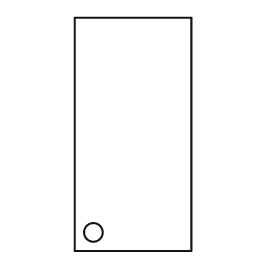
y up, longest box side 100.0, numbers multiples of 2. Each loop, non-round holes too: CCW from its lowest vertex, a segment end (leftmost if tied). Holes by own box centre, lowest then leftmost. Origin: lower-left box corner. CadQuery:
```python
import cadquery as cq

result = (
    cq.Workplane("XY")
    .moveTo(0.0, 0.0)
    .lineTo(50.0, 0.0)
    .lineTo(50.0, 100.0)
    .lineTo(0.0, 100.0)
    .close()
    .moveTo(8.0, 8.0)
    .circle(4.0)
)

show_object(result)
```